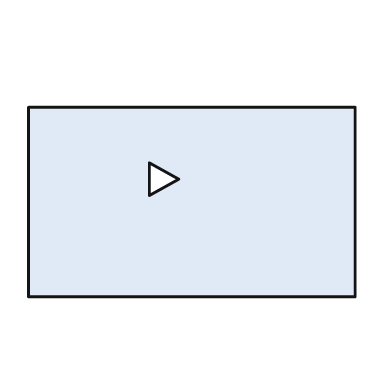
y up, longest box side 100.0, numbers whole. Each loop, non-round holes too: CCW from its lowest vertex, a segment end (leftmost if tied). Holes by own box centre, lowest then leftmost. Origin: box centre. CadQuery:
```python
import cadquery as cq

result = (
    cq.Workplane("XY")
    .moveTo(-50.0, -29.0)
    .lineTo(50.0, -29.0)
    .lineTo(50.0, 29.0)
    .lineTo(-50.0, 29.0)
    .close()
    .moveTo(-13.0, 2.0)
    .lineTo(-4.0, 7.0)
    .lineTo(-13.0, 12.0)
    .close()
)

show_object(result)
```